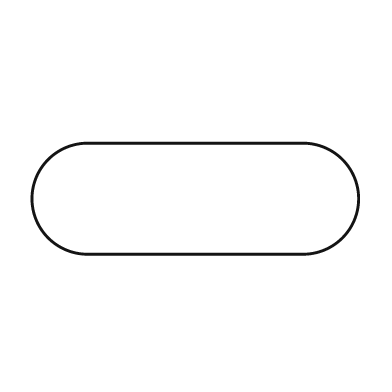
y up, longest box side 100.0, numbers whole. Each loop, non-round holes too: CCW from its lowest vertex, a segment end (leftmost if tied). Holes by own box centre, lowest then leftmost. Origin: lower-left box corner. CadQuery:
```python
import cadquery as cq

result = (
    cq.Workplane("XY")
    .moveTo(17.0, 0.0)
    .lineTo(83.0, 0.0)
    .threePointArc((100.0, 17.0), (83.0, 34.0))
    .lineTo(17.0, 34.0)
    .threePointArc((0.0, 17.0), (17.0, 0.0))
    .close()
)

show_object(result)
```